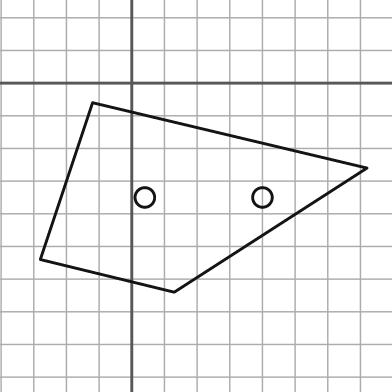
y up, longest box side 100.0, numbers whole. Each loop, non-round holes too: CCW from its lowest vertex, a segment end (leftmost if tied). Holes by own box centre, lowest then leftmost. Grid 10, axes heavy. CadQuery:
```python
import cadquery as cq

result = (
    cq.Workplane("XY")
    .moveTo(13.0, -64.0)
    .lineTo(72.0, -26.0)
    .lineTo(-12.0, -6.0)
    .lineTo(-28.0, -54.0)
    .close()
    .moveTo(4.0, -35.0)
    .circle(3.0)
    .moveTo(40.0, -35.0)
    .circle(3.0)
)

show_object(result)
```